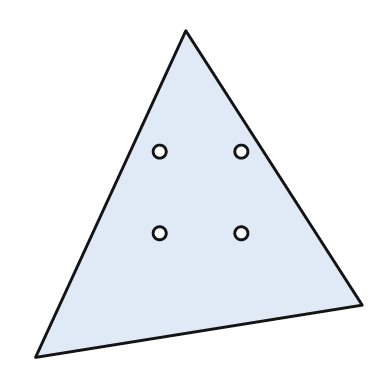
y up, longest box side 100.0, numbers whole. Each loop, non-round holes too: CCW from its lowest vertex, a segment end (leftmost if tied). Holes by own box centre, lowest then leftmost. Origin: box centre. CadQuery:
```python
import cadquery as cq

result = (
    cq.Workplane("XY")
    .moveTo(-50.0, -50.0)
    .lineTo(50.0, -34.0)
    .lineTo(-4.0, 50.0)
    .close()
    .moveTo(-12.0, -12.0)
    .circle(2.0)
    .moveTo(13.0, -12.0)
    .circle(2.0)
    .moveTo(-12.0, 13.0)
    .circle(2.0)
    .moveTo(13.0, 13.0)
    .circle(2.0)
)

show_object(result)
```